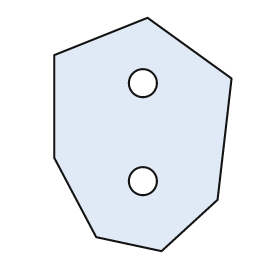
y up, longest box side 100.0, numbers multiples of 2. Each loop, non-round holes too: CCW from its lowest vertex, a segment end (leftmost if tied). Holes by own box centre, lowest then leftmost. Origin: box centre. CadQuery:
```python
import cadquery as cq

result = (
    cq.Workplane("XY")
    .moveTo(8.0, -50.0)
    .lineTo(32.0, -28.0)
    .lineTo(38.0, 24.0)
    .lineTo(2.0, 50.0)
    .lineTo(-38.0, 34.0)
    .lineTo(-38.0, -10.0)
    .lineTo(-20.0, -44.0)
    .close()
    .moveTo(0.0, -20.0)
    .circle(6.0)
    .moveTo(0.0, 22.0)
    .circle(6.0)
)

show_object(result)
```